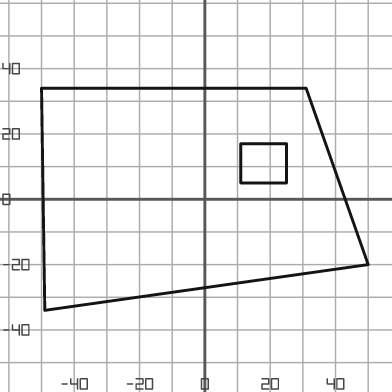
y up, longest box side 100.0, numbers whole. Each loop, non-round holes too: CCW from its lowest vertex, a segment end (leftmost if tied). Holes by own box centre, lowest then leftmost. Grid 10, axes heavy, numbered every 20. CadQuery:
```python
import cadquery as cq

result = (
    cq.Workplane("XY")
    .moveTo(-49.0, -34.0)
    .lineTo(50.0, -20.0)
    .lineTo(31.0, 34.0)
    .lineTo(-50.0, 34.0)
    .close()
    .moveTo(11.0, 5.0)
    .lineTo(25.0, 5.0)
    .lineTo(25.0, 17.0)
    .lineTo(11.0, 17.0)
    .close()
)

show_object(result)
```